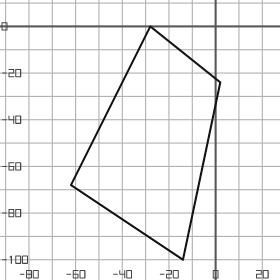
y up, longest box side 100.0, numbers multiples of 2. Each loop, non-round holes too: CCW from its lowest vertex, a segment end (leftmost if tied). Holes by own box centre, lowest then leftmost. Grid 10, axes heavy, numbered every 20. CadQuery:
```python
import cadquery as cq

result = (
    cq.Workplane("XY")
    .moveTo(-14.0, -100.0)
    .lineTo(2.0, -24.0)
    .lineTo(-28.0, 0.0)
    .lineTo(-62.0, -68.0)
    .close()
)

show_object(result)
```